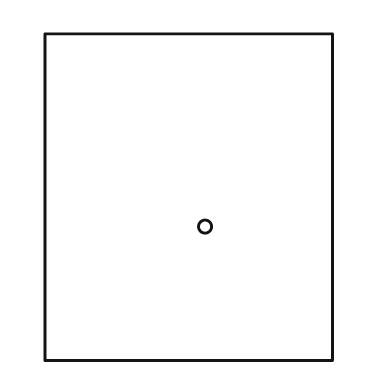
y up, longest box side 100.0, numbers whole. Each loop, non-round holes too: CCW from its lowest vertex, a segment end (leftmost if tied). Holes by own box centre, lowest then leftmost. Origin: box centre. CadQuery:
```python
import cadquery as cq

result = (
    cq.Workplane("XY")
    .moveTo(-44.0, -50.0)
    .lineTo(44.0, -50.0)
    .lineTo(44.0, 50.0)
    .lineTo(-44.0, 50.0)
    .close()
    .moveTo(5.0, -9.0)
    .circle(2.0)
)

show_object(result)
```